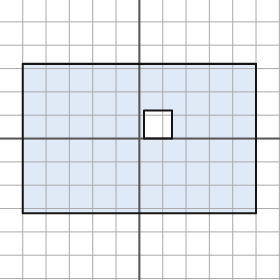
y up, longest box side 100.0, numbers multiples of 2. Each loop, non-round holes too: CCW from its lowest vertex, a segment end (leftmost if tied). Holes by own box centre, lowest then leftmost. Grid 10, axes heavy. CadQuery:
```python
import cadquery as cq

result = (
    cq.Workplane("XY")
    .moveTo(-50.0, -32.0)
    .lineTo(50.0, -32.0)
    .lineTo(50.0, 32.0)
    .lineTo(-50.0, 32.0)
    .close()
    .moveTo(2.0, 0.0)
    .lineTo(14.0, 0.0)
    .lineTo(14.0, 12.0)
    .lineTo(2.0, 12.0)
    .close()
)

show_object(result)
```